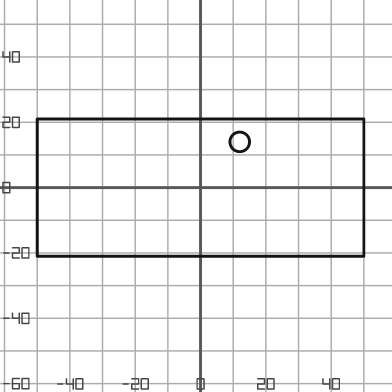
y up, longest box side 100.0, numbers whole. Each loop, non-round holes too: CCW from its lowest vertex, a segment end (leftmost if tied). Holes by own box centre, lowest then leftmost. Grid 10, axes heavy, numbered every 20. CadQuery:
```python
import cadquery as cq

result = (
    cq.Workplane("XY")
    .moveTo(-50.0, -21.0)
    .lineTo(50.0, -21.0)
    .lineTo(50.0, 21.0)
    .lineTo(-50.0, 21.0)
    .close()
    .moveTo(12.0, 14.0)
    .circle(3.0)
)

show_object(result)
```